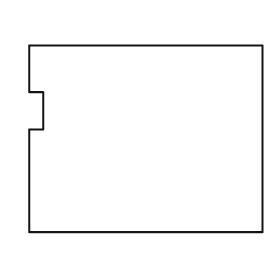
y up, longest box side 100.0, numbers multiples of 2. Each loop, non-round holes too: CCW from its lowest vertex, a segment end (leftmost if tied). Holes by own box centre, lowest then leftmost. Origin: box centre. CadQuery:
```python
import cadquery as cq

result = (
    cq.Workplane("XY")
    .moveTo(-50.0, -40.0)
    .lineTo(50.0, -40.0)
    .lineTo(50.0, 40.0)
    .lineTo(-50.0, 40.0)
    .lineTo(-50.0, 20.0)
    .lineTo(-44.0, 20.0)
    .lineTo(-44.0, 4.0)
    .lineTo(-50.0, 4.0)
    .close()
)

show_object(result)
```